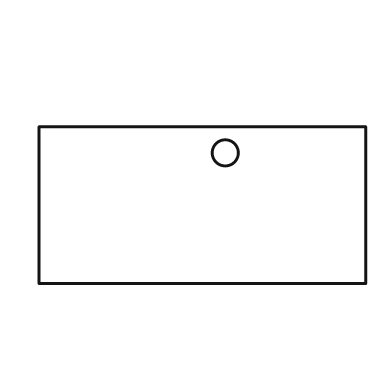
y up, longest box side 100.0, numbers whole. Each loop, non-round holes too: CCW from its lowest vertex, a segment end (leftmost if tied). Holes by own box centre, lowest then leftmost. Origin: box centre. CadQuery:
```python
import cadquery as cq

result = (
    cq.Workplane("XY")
    .moveTo(-50.0, -24.0)
    .lineTo(50.0, -24.0)
    .lineTo(50.0, 24.0)
    .lineTo(-50.0, 24.0)
    .close()
    .moveTo(7.0, 16.0)
    .circle(4.0)
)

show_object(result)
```